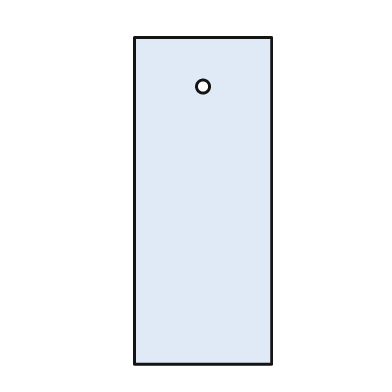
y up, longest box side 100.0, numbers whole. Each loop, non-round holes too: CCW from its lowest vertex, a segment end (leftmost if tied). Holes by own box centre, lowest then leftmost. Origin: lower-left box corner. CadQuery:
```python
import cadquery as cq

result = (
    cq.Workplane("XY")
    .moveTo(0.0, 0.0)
    .lineTo(42.0, 0.0)
    .lineTo(42.0, 100.0)
    .lineTo(0.0, 100.0)
    .close()
    .moveTo(21.0, 85.0)
    .circle(2.0)
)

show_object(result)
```